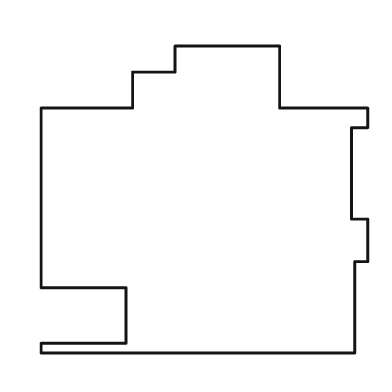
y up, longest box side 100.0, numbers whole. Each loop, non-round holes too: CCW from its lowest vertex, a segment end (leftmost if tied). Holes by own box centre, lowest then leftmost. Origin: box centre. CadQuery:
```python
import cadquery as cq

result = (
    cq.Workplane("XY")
    .moveTo(-50.0, -47.0)
    .lineTo(46.0, -47.0)
    .lineTo(46.0, -19.0)
    .lineTo(50.0, -19.0)
    .lineTo(50.0, -6.0)
    .lineTo(45.0, -6.0)
    .lineTo(45.0, 22.0)
    .lineTo(50.0, 22.0)
    .lineTo(50.0, 28.0)
    .lineTo(23.0, 28.0)
    .lineTo(23.0, 47.0)
    .lineTo(-9.0, 47.0)
    .lineTo(-9.0, 39.0)
    .lineTo(-22.0, 39.0)
    .lineTo(-22.0, 28.0)
    .lineTo(-50.0, 28.0)
    .lineTo(-50.0, -27.0)
    .lineTo(-24.0, -27.0)
    .lineTo(-24.0, -44.0)
    .lineTo(-50.0, -44.0)
    .close()
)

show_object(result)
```